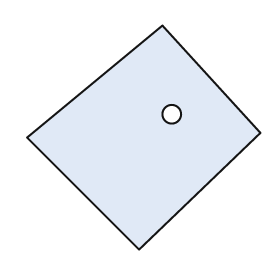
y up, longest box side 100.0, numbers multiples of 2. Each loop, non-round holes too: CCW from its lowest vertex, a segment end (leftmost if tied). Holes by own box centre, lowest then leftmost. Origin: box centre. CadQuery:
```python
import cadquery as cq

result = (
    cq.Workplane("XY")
    .moveTo(-2.0, -48.0)
    .lineTo(50.0, 2.0)
    .lineTo(8.0, 48.0)
    .lineTo(-50.0, 0.0)
    .close()
    .moveTo(12.0, 10.0)
    .circle(4.0)
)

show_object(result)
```